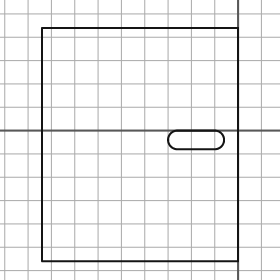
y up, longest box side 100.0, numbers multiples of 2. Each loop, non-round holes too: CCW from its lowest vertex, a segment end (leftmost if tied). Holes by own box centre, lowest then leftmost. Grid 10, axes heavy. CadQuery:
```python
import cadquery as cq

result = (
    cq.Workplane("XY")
    .moveTo(-84.0, -56.0)
    .lineTo(0.0, -56.0)
    .lineTo(0.0, 44.0)
    .lineTo(-84.0, 44.0)
    .close()
    .moveTo(-26.0, -8.0)
    .lineTo(-10.0, -8.0)
    .threePointArc((-6.0, -4.0), (-10.0, 0.0))
    .lineTo(-26.0, 0.0)
    .threePointArc((-30.0, -4.0), (-26.0, -8.0))
    .close()
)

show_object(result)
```